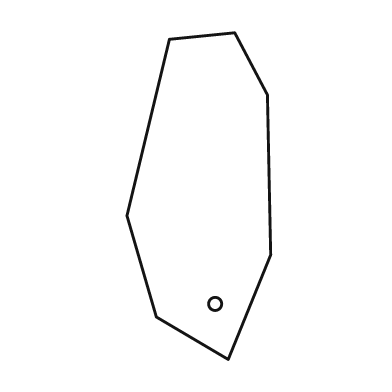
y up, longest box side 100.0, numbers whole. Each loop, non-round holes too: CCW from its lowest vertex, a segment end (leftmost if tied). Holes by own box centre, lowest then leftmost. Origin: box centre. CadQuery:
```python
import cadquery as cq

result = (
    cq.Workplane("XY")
    .moveTo(9.0, -50.0)
    .lineTo(22.0, -18.0)
    .lineTo(21.0, 31.0)
    .lineTo(11.0, 50.0)
    .lineTo(-9.0, 48.0)
    .lineTo(-22.0, -6.0)
    .lineTo(-13.0, -37.0)
    .close()
    .moveTo(5.0, -33.0)
    .circle(2.0)
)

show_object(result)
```